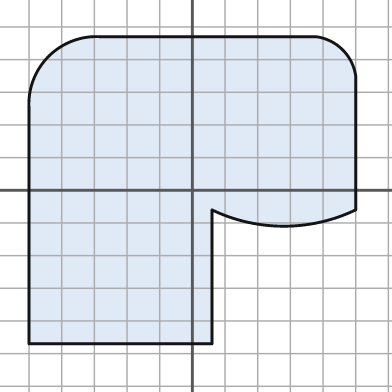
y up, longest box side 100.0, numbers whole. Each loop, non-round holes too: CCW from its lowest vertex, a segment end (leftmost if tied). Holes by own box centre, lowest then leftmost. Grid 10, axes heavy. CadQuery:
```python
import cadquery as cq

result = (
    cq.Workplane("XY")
    .moveTo(-50.0, -47.0)
    .lineTo(6.0, -47.0)
    .lineTo(6.0, -6.0)
    .threePointArc((28.0, -11.0), (50.0, -6.0))
    .lineTo(50.0, 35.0)
    .threePointArc((46.0, 43.0), (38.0, 47.0))
    .lineTo(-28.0, 47.0)
    .threePointArc((-44.0, 41.0), (-50.0, 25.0))
    .close()
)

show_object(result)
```